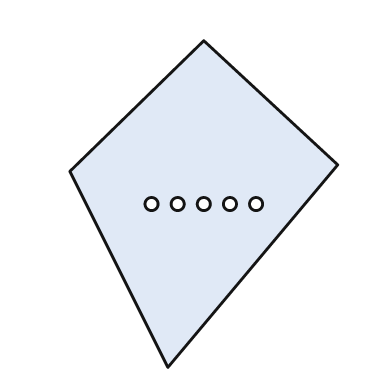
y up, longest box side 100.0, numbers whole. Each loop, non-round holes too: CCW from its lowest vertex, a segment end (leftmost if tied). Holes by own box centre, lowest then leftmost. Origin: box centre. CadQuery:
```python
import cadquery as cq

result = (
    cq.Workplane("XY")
    .moveTo(-11.0, -50.0)
    .lineTo(41.0, 12.0)
    .lineTo(0.0, 50.0)
    .lineTo(-41.0, 10.0)
    .close()
    .moveTo(-16.0, 0.0)
    .circle(2.0)
    .moveTo(-8.0, 0.0)
    .circle(2.0)
    .moveTo(0.0, 0.0)
    .circle(2.0)
    .moveTo(8.0, 0.0)
    .circle(2.0)
    .moveTo(16.0, 0.0)
    .circle(2.0)
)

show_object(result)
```